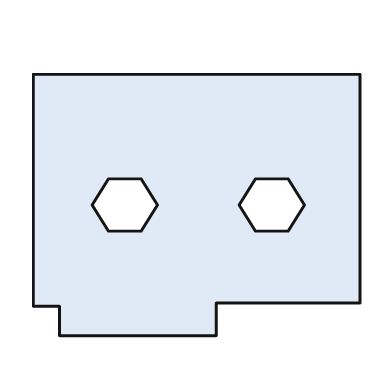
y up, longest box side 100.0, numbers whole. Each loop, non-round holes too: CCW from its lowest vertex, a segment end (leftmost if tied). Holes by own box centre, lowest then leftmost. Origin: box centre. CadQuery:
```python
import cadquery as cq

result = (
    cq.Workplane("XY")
    .moveTo(-42.0, -40.0)
    .lineTo(6.0, -40.0)
    .lineTo(6.0, -30.0)
    .lineTo(50.0, -30.0)
    .lineTo(50.0, 40.0)
    .lineTo(-50.0, 40.0)
    .lineTo(-50.0, -31.0)
    .lineTo(-42.0, -31.0)
    .close()
    .moveTo(-27.0, -8.0)
    .lineTo(-17.0, -8.0)
    .lineTo(-12.0, 0.0)
    .lineTo(-17.0, 8.0)
    .lineTo(-27.0, 8.0)
    .lineTo(-32.0, 0.0)
    .close()
    .moveTo(18.0, -8.0)
    .lineTo(28.0, -8.0)
    .lineTo(33.0, 0.0)
    .lineTo(28.0, 8.0)
    .lineTo(18.0, 8.0)
    .lineTo(13.0, 0.0)
    .close()
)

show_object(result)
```